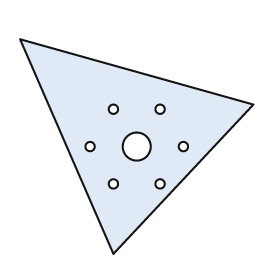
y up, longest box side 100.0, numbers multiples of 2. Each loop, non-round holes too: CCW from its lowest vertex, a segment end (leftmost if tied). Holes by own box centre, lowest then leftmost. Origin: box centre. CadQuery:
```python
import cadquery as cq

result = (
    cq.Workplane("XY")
    .moveTo(-10.0, -46.0)
    .lineTo(50.0, 18.0)
    .lineTo(-50.0, 46.0)
    .close()
    .moveTo(-10.0, -16.0)
    .circle(2.0)
    .moveTo(10.0, -16.0)
    .circle(2.0)
    .moveTo(-20.0, 0.0)
    .circle(2.0)
    .moveTo(0.0, 0.0)
    .circle(6.0)
    .moveTo(20.0, 0.0)
    .circle(2.0)
    .moveTo(-10.0, 16.0)
    .circle(2.0)
    .moveTo(10.0, 16.0)
    .circle(2.0)
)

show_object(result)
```